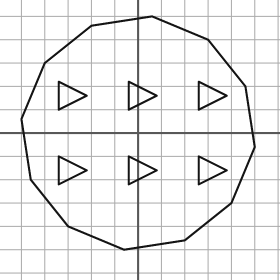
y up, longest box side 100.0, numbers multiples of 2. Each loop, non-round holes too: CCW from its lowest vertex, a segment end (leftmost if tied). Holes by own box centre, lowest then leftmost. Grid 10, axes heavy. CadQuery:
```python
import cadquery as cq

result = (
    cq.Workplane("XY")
    .moveTo(-6.0, -50.0)
    .lineTo(20.0, -46.0)
    .lineTo(40.0, -30.0)
    .lineTo(50.0, -6.0)
    .lineTo(46.0, 20.0)
    .lineTo(30.0, 40.0)
    .lineTo(6.0, 50.0)
    .lineTo(-20.0, 46.0)
    .lineTo(-40.0, 30.0)
    .lineTo(-50.0, 6.0)
    .lineTo(-46.0, -20.0)
    .lineTo(-30.0, -40.0)
    .close()
    .moveTo(-34.0, -22.0)
    .lineTo(-22.0, -16.0)
    .lineTo(-34.0, -10.0)
    .close()
    .moveTo(-4.0, -22.0)
    .lineTo(8.0, -16.0)
    .lineTo(-4.0, -10.0)
    .close()
    .moveTo(26.0, -22.0)
    .lineTo(38.0, -16.0)
    .lineTo(26.0, -10.0)
    .close()
    .moveTo(-34.0, 10.0)
    .lineTo(-22.0, 16.0)
    .lineTo(-34.0, 22.0)
    .close()
    .moveTo(-4.0, 10.0)
    .lineTo(8.0, 16.0)
    .lineTo(-4.0, 22.0)
    .close()
    .moveTo(26.0, 10.0)
    .lineTo(38.0, 16.0)
    .lineTo(26.0, 22.0)
    .close()
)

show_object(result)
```